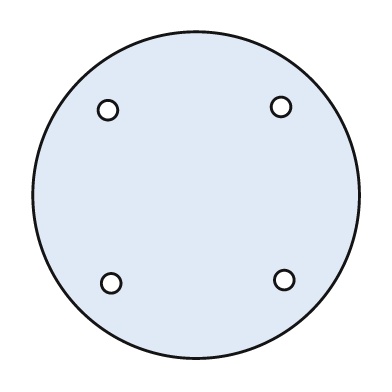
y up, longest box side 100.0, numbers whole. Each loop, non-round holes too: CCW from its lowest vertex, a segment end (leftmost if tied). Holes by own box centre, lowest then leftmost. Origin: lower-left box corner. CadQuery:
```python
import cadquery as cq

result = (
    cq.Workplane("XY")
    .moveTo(50.0, 50.0)
    .circle(50.0)
    .moveTo(24.0, 23.0)
    .circle(3.0)
    .moveTo(77.0, 24.0)
    .circle(3.0)
    .moveTo(23.0, 76.0)
    .circle(3.0)
    .moveTo(76.0, 77.0)
    .circle(3.0)
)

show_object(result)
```